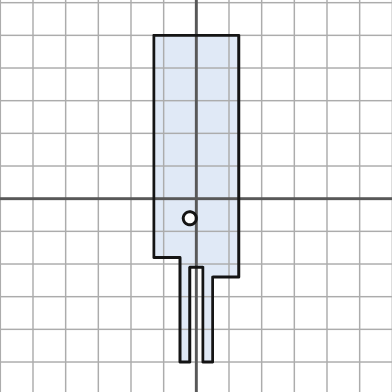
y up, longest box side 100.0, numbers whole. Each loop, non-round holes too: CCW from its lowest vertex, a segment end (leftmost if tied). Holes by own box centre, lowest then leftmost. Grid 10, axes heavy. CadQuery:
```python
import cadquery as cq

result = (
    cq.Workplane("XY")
    .moveTo(-5.0, -50.0)
    .lineTo(-2.0, -50.0)
    .lineTo(-2.0, -21.0)
    .lineTo(2.0, -21.0)
    .lineTo(2.0, -50.0)
    .lineTo(5.0, -50.0)
    .lineTo(5.0, -24.0)
    .lineTo(13.0, -24.0)
    .lineTo(13.0, 50.0)
    .lineTo(-13.0, 50.0)
    .lineTo(-13.0, -18.0)
    .lineTo(-5.0, -18.0)
    .close()
    .moveTo(-2.0, -6.0)
    .circle(2.0)
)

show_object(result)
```